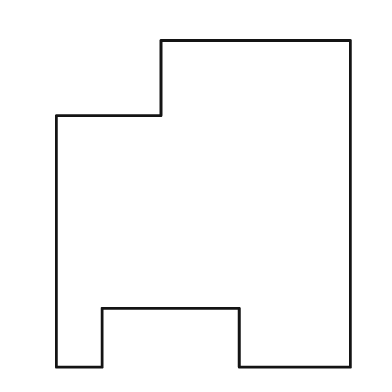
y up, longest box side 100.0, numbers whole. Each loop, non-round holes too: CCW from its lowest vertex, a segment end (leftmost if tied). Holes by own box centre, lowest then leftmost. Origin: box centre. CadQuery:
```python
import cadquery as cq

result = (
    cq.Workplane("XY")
    .moveTo(-45.0, -50.0)
    .lineTo(-31.0, -50.0)
    .lineTo(-31.0, -32.0)
    .lineTo(11.0, -32.0)
    .lineTo(11.0, -50.0)
    .lineTo(45.0, -50.0)
    .lineTo(45.0, 50.0)
    .lineTo(-13.0, 50.0)
    .lineTo(-13.0, 27.0)
    .lineTo(-45.0, 27.0)
    .close()
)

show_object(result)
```